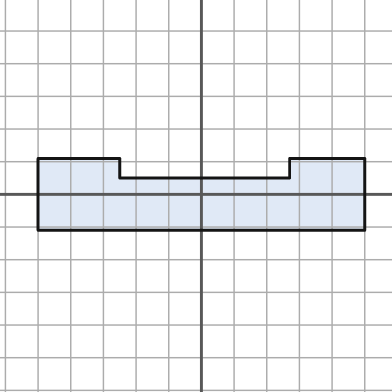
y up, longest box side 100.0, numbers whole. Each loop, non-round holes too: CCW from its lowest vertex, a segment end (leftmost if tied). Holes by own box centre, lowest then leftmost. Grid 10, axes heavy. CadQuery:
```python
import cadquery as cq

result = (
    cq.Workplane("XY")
    .moveTo(-50.0, -11.0)
    .lineTo(50.0, -11.0)
    .lineTo(50.0, 11.0)
    .lineTo(27.0, 11.0)
    .lineTo(27.0, 5.0)
    .lineTo(-25.0, 5.0)
    .lineTo(-25.0, 11.0)
    .lineTo(-50.0, 11.0)
    .close()
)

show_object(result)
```